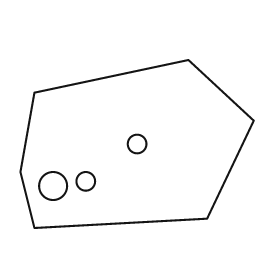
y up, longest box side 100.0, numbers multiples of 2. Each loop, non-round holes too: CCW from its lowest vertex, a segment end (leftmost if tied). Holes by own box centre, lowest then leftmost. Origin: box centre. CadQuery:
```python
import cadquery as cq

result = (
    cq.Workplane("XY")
    .moveTo(-44.0, -36.0)
    .lineTo(30.0, -32.0)
    .lineTo(50.0, 10.0)
    .lineTo(22.0, 36.0)
    .lineTo(-44.0, 22.0)
    .lineTo(-50.0, -12.0)
    .close()
    .moveTo(-36.0, -18.0)
    .circle(6.0)
    .moveTo(-22.0, -16.0)
    .circle(4.0)
    .moveTo(0.0, 0.0)
    .circle(4.0)
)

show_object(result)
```